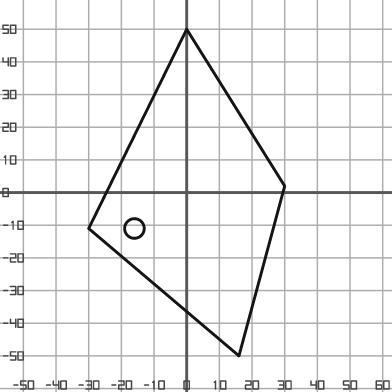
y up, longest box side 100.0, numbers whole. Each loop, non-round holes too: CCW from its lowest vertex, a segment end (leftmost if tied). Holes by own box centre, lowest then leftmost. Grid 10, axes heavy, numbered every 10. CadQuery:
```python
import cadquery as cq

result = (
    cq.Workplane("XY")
    .moveTo(16.0, -50.0)
    .lineTo(30.0, 2.0)
    .lineTo(0.0, 50.0)
    .lineTo(-30.0, -11.0)
    .close()
    .moveTo(-16.0, -11.0)
    .circle(3.0)
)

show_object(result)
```